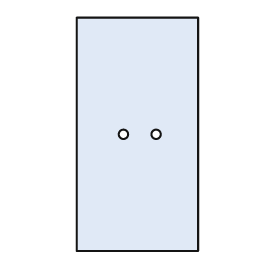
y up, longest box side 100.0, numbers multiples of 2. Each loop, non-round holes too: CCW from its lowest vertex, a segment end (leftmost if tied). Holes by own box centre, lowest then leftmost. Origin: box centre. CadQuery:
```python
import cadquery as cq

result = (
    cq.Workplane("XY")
    .moveTo(-26.0, -50.0)
    .lineTo(26.0, -50.0)
    .lineTo(26.0, 50.0)
    .lineTo(-26.0, 50.0)
    .close()
    .moveTo(-6.0, 0.0)
    .circle(2.0)
    .moveTo(8.0, 0.0)
    .circle(2.0)
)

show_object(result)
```